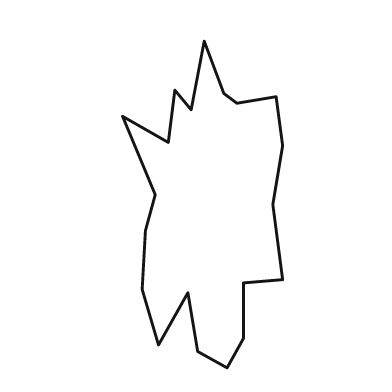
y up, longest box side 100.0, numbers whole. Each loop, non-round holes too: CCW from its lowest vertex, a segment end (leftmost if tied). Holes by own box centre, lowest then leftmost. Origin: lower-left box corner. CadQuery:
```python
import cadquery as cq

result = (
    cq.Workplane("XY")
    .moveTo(32.0, 0.0)
    .lineTo(37.0, 9.0)
    .lineTo(37.0, 26.0)
    .lineTo(49.0, 27.0)
    .lineTo(46.0, 50.0)
    .lineTo(49.0, 68.0)
    .lineTo(47.0, 83.0)
    .lineTo(35.0, 81.0)
    .lineTo(31.0, 84.0)
    .lineTo(25.0, 100.0)
    .lineTo(21.0, 79.0)
    .lineTo(16.0, 85.0)
    .lineTo(14.0, 69.0)
    .lineTo(0.0, 77.0)
    .lineTo(10.0, 53.0)
    .lineTo(7.0, 42.0)
    .lineTo(6.0, 24.0)
    .lineTo(11.0, 7.0)
    .lineTo(20.0, 23.0)
    .lineTo(23.0, 5.0)
    .close()
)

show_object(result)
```